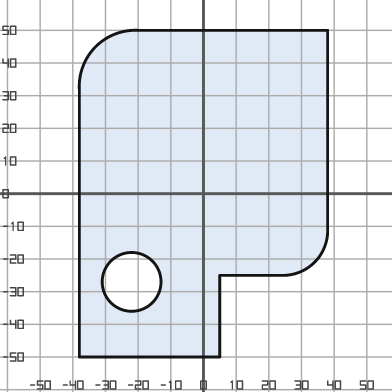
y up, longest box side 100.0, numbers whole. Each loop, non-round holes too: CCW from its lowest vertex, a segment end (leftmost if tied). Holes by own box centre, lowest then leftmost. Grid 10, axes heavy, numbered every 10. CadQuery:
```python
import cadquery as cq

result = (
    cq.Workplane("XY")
    .moveTo(-38.0, -50.0)
    .lineTo(5.0, -50.0)
    .lineTo(5.0, -25.0)
    .lineTo(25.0, -25.0)
    .threePointArc((34.0, -21.0), (38.0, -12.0))
    .lineTo(38.0, 50.0)
    .lineTo(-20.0, 50.0)
    .threePointArc((-33.0, 45.0), (-38.0, 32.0))
    .close()
    .moveTo(-22.0, -27.0)
    .circle(9.0)
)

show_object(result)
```